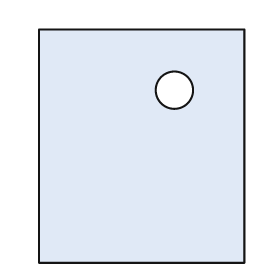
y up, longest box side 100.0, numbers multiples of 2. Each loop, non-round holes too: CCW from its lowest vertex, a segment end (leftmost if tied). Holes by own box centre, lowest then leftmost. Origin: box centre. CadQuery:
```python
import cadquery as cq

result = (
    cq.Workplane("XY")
    .moveTo(-44.0, -50.0)
    .lineTo(44.0, -50.0)
    .lineTo(44.0, 50.0)
    .lineTo(-44.0, 50.0)
    .close()
    .moveTo(14.0, 24.0)
    .circle(8.0)
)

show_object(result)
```